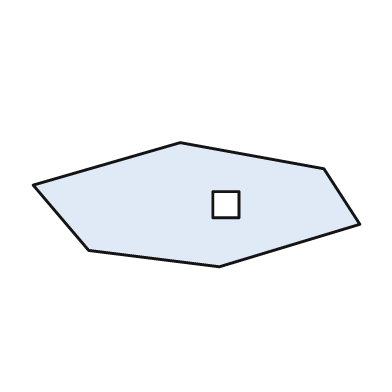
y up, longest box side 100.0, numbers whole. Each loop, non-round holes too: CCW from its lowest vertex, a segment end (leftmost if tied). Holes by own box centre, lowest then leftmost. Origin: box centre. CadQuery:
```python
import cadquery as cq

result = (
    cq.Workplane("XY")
    .moveTo(7.0, -19.0)
    .lineTo(50.0, -6.0)
    .lineTo(39.0, 11.0)
    .lineTo(-5.0, 19.0)
    .lineTo(-50.0, 6.0)
    .lineTo(-33.0, -14.0)
    .close()
    .moveTo(5.0, -4.0)
    .lineTo(13.0, -4.0)
    .lineTo(13.0, 4.0)
    .lineTo(5.0, 4.0)
    .close()
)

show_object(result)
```